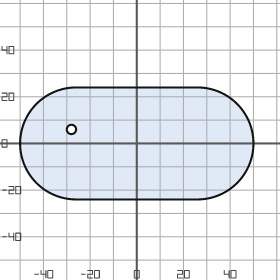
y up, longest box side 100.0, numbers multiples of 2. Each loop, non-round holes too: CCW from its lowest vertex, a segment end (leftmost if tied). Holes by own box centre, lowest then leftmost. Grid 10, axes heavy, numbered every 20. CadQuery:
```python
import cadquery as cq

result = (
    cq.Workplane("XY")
    .moveTo(-26.0, -24.0)
    .lineTo(26.0, -24.0)
    .threePointArc((50.0, 0.0), (26.0, 24.0))
    .lineTo(-26.0, 24.0)
    .threePointArc((-50.0, 0.0), (-26.0, -24.0))
    .close()
    .moveTo(-28.0, 6.0)
    .circle(2.0)
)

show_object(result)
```